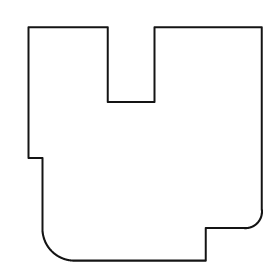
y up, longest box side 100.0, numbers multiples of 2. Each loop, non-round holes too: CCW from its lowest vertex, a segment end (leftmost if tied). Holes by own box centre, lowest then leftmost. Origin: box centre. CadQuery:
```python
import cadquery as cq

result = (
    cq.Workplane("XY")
    .moveTo(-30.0, -50.0)
    .lineTo(26.0, -50.0)
    .lineTo(26.0, -36.0)
    .lineTo(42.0, -36.0)
    .threePointArc((48.0, -34.0), (50.0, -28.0))
    .lineTo(50.0, 50.0)
    .lineTo(4.0, 50.0)
    .lineTo(4.0, 18.0)
    .lineTo(-16.0, 18.0)
    .lineTo(-16.0, 50.0)
    .lineTo(-50.0, 50.0)
    .lineTo(-50.0, -6.0)
    .lineTo(-44.0, -6.0)
    .lineTo(-44.0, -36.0)
    .threePointArc((-40.0, -46.0), (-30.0, -50.0))
    .close()
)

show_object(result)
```